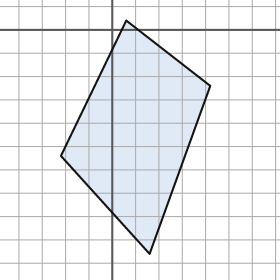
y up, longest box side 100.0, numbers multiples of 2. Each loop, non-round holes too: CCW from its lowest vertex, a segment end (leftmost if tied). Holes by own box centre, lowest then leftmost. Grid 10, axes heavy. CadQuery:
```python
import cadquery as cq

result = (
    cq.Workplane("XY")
    .moveTo(16.0, -96.0)
    .lineTo(42.0, -24.0)
    .lineTo(6.0, 4.0)
    .lineTo(-22.0, -54.0)
    .close()
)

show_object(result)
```